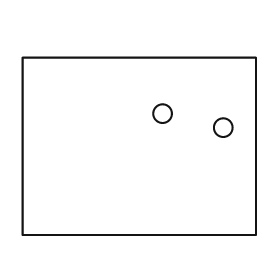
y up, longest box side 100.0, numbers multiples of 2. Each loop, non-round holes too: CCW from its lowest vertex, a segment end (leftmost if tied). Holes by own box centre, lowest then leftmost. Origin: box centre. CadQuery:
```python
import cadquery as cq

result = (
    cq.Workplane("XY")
    .moveTo(-50.0, -38.0)
    .lineTo(50.0, -38.0)
    .lineTo(50.0, 38.0)
    .lineTo(-50.0, 38.0)
    .close()
    .moveTo(36.0, 8.0)
    .circle(4.0)
    .moveTo(10.0, 14.0)
    .circle(4.0)
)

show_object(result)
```